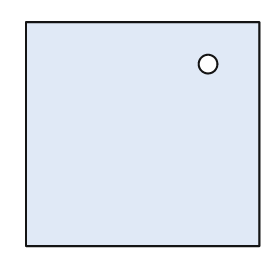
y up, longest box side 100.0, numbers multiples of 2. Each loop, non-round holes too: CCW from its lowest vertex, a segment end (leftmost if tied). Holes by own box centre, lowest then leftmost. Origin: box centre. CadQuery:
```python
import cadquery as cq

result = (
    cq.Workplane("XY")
    .moveTo(-50.0, -48.0)
    .lineTo(50.0, -48.0)
    .lineTo(50.0, 48.0)
    .lineTo(-50.0, 48.0)
    .close()
    .moveTo(28.0, 30.0)
    .circle(4.0)
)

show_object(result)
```